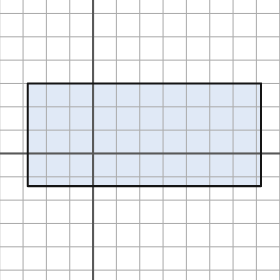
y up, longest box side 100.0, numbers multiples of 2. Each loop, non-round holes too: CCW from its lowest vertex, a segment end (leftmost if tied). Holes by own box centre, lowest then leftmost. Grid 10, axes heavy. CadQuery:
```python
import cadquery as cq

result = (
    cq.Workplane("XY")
    .moveTo(-28.0, -14.0)
    .lineTo(72.0, -14.0)
    .lineTo(72.0, 30.0)
    .lineTo(-28.0, 30.0)
    .close()
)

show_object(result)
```